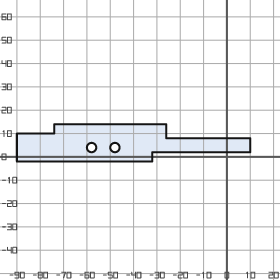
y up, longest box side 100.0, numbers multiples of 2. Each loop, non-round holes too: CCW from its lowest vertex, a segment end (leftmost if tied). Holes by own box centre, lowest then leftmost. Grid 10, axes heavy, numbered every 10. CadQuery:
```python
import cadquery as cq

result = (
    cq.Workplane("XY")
    .moveTo(-90.0, -2.0)
    .lineTo(-32.0, -2.0)
    .lineTo(-32.0, 2.0)
    .lineTo(10.0, 2.0)
    .lineTo(10.0, 8.0)
    .lineTo(-26.0, 8.0)
    .lineTo(-26.0, 14.0)
    .lineTo(-74.0, 14.0)
    .lineTo(-74.0, 10.0)
    .lineTo(-90.0, 10.0)
    .close()
    .moveTo(-58.0, 4.0)
    .circle(2.0)
    .moveTo(-48.0, 4.0)
    .circle(2.0)
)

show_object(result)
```